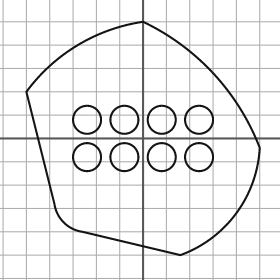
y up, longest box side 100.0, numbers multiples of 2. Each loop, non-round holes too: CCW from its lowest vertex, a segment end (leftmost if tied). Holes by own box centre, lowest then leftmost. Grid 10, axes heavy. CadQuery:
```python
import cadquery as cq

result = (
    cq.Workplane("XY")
    .moveTo(16.0, -50.0)
    .threePointArc((40.0, -32.0), (50.0, -4.0))
    .threePointArc((30.0, 28.0), (0.0, 50.0))
    .threePointArc((-28.0, 40.0), (-50.0, 20.0))
    .lineTo(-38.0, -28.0)
    .threePointArc((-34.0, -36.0), (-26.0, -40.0))
    .close()
    .moveTo(-24.0, -8.0)
    .circle(6.0)
    .moveTo(-8.0, -8.0)
    .circle(6.0)
    .moveTo(8.0, -8.0)
    .circle(6.0)
    .moveTo(24.0, -8.0)
    .circle(6.0)
    .moveTo(-24.0, 8.0)
    .circle(6.0)
    .moveTo(-8.0, 8.0)
    .circle(6.0)
    .moveTo(8.0, 8.0)
    .circle(6.0)
    .moveTo(24.0, 8.0)
    .circle(6.0)
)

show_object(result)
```